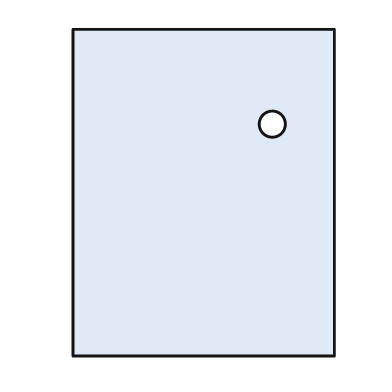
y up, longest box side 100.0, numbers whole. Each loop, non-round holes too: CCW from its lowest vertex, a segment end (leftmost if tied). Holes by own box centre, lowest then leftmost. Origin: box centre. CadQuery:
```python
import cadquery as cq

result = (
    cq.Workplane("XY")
    .moveTo(-40.0, -50.0)
    .lineTo(40.0, -50.0)
    .lineTo(40.0, 50.0)
    .lineTo(-40.0, 50.0)
    .close()
    .moveTo(21.0, 21.0)
    .circle(4.0)
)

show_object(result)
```